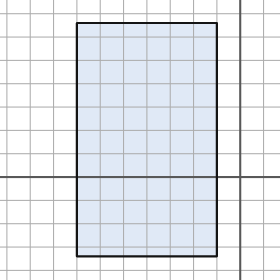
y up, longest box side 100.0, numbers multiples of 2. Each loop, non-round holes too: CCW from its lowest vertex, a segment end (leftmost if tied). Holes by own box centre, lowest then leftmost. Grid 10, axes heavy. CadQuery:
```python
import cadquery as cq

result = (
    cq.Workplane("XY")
    .moveTo(-70.0, -34.0)
    .lineTo(-10.0, -34.0)
    .lineTo(-10.0, 66.0)
    .lineTo(-70.0, 66.0)
    .close()
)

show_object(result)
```